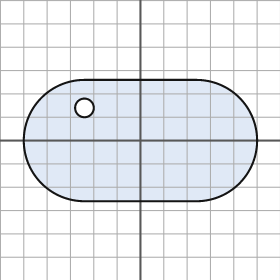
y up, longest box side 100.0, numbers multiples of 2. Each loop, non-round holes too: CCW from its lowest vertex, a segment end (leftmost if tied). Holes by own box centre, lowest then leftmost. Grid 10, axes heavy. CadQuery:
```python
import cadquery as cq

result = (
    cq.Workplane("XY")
    .moveTo(-24.0, -26.0)
    .lineTo(24.0, -26.0)
    .threePointArc((50.0, 0.0), (24.0, 26.0))
    .lineTo(-24.0, 26.0)
    .threePointArc((-50.0, 0.0), (-24.0, -26.0))
    .close()
    .moveTo(-24.0, 14.0)
    .circle(4.0)
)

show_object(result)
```